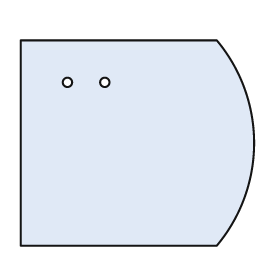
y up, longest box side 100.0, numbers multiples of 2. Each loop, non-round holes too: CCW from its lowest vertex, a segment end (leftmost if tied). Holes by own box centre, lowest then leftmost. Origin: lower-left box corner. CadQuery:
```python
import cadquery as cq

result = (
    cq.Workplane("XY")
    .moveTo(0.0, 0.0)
    .lineTo(84.0, 0.0)
    .threePointArc((100.0, 44.0), (84.0, 88.0))
    .lineTo(0.0, 88.0)
    .close()
    .moveTo(20.0, 70.0)
    .circle(2.0)
    .moveTo(36.0, 70.0)
    .circle(2.0)
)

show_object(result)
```